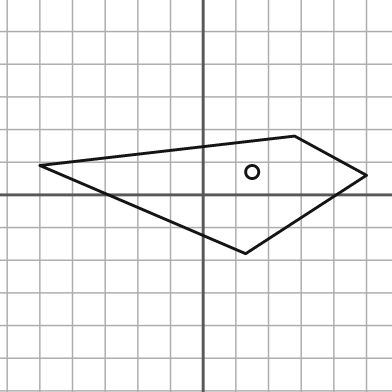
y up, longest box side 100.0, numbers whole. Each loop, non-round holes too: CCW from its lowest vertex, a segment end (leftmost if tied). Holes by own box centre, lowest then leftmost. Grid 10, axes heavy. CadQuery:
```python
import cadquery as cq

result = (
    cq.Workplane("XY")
    .moveTo(13.0, -18.0)
    .lineTo(50.0, 6.0)
    .lineTo(28.0, 18.0)
    .lineTo(-50.0, 9.0)
    .close()
    .moveTo(15.0, 7.0)
    .circle(2.0)
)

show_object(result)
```